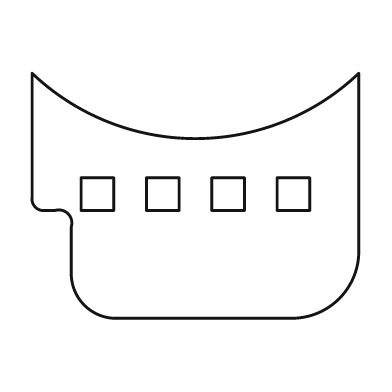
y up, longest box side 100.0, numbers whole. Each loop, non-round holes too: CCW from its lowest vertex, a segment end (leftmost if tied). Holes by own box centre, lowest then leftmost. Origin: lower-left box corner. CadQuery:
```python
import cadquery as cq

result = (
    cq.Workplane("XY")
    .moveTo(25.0, 0.0)
    .lineTo(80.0, 0.0)
    .threePointArc((94.0, 6.0), (100.0, 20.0))
    .lineTo(100.0, 75.0)
    .threePointArc((50.0, 55.0), (0.0, 75.0))
    .lineTo(0.0, 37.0)
    .threePointArc((1.0, 34.0), (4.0, 33.0))
    .lineTo(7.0, 33.0)
    .threePointArc((11.0, 32.0), (12.0, 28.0))
    .lineTo(12.0, 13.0)
    .threePointArc((16.0, 4.0), (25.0, 0.0))
    .close()
    .moveTo(15.0, 33.0)
    .lineTo(25.0, 33.0)
    .lineTo(25.0, 43.0)
    .lineTo(15.0, 43.0)
    .close()
    .moveTo(35.0, 33.0)
    .lineTo(45.0, 33.0)
    .lineTo(45.0, 43.0)
    .lineTo(35.0, 43.0)
    .close()
    .moveTo(55.0, 33.0)
    .lineTo(65.0, 33.0)
    .lineTo(65.0, 43.0)
    .lineTo(55.0, 43.0)
    .close()
    .moveTo(75.0, 33.0)
    .lineTo(85.0, 33.0)
    .lineTo(85.0, 43.0)
    .lineTo(75.0, 43.0)
    .close()
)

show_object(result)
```